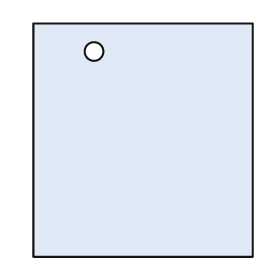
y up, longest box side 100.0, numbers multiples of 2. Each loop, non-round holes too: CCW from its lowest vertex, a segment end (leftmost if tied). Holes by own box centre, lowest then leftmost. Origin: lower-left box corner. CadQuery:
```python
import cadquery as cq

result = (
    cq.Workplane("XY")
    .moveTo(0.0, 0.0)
    .lineTo(94.0, 0.0)
    .lineTo(94.0, 100.0)
    .lineTo(0.0, 100.0)
    .close()
    .moveTo(26.0, 88.0)
    .circle(4.0)
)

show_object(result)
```